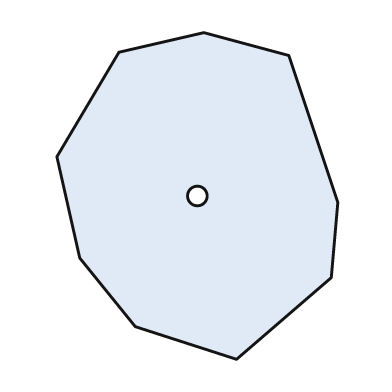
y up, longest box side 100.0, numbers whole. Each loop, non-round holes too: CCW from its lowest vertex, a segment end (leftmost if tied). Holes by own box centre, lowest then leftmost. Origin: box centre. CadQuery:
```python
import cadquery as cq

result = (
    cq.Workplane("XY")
    .moveTo(12.0, -50.0)
    .lineTo(41.0, -25.0)
    .lineTo(43.0, -2.0)
    .lineTo(28.0, 43.0)
    .lineTo(2.0, 50.0)
    .lineTo(-24.0, 44.0)
    .lineTo(-43.0, 12.0)
    .lineTo(-36.0, -19.0)
    .lineTo(-19.0, -40.0)
    .close()
    .moveTo(0.0, 0.0)
    .circle(3.0)
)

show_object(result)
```